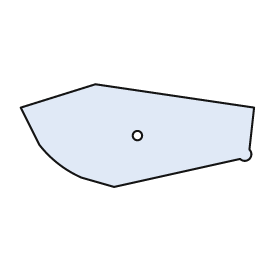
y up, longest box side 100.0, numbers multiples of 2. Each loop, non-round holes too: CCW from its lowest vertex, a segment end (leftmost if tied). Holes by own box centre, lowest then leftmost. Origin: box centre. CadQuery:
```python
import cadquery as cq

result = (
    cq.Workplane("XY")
    .moveTo(-10.0, -22.0)
    .lineTo(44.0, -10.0)
    .threePointArc((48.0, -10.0), (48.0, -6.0))
    .lineTo(50.0, 12.0)
    .lineTo(-18.0, 22.0)
    .lineTo(-50.0, 12.0)
    .lineTo(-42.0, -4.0)
    .threePointArc((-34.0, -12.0), (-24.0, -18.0))
    .close()
    .moveTo(0.0, 0.0)
    .circle(2.0)
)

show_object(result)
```